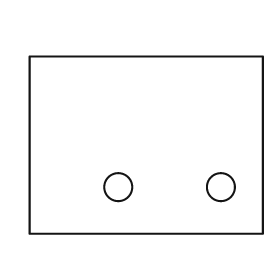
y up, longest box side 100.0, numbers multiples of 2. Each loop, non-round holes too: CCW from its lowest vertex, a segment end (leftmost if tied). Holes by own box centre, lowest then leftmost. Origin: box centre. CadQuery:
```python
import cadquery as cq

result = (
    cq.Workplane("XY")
    .moveTo(-50.0, -38.0)
    .lineTo(50.0, -38.0)
    .lineTo(50.0, 38.0)
    .lineTo(-50.0, 38.0)
    .close()
    .moveTo(-12.0, -18.0)
    .circle(6.0)
    .moveTo(32.0, -18.0)
    .circle(6.0)
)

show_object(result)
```